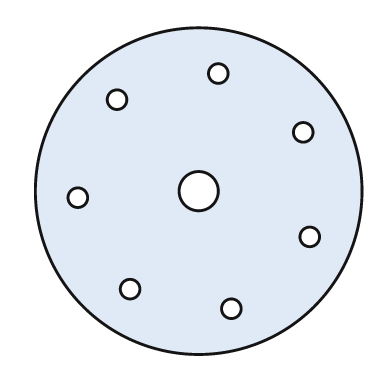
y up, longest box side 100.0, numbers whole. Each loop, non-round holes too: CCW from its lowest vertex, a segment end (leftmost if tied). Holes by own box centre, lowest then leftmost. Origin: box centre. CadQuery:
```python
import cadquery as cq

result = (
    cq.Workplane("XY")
    .moveTo(0.0, 0.0)
    .circle(50.0)
    .moveTo(10.0, -36.0)
    .circle(3.0)
    .moveTo(-21.0, -30.0)
    .circle(3.0)
    .moveTo(34.0, -14.0)
    .circle(3.0)
    .moveTo(-37.0, -2.0)
    .circle(3.0)
    .moveTo(0.0, 0.0)
    .circle(6.0)
    .moveTo(32.0, 18.0)
    .circle(3.0)
    .moveTo(-25.0, 28.0)
    .circle(3.0)
    .moveTo(6.0, 36.0)
    .circle(3.0)
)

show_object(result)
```